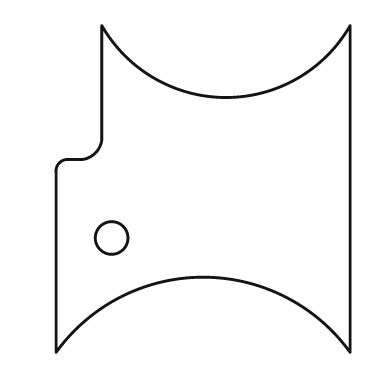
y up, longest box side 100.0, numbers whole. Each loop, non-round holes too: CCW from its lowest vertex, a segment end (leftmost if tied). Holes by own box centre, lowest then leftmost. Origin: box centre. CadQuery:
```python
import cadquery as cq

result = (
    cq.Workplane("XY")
    .moveTo(-45.0, -50.0)
    .threePointArc((0.0, -27.0), (45.0, -50.0))
    .lineTo(45.0, 50.0)
    .threePointArc((7.0, 28.0), (-31.0, 50.0))
    .lineTo(-31.0, 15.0)
    .threePointArc((-33.0, 11.0), (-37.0, 9.0))
    .lineTo(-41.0, 9.0)
    .threePointArc((-44.0, 8.0), (-45.0, 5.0))
    .close()
    .moveTo(-28.0, -15.0)
    .circle(5.0)
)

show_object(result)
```